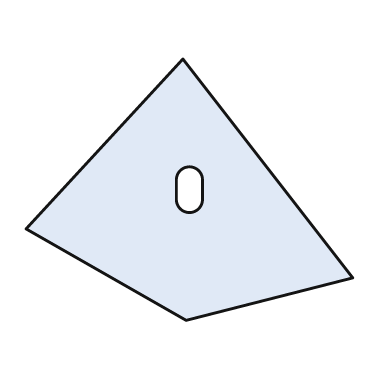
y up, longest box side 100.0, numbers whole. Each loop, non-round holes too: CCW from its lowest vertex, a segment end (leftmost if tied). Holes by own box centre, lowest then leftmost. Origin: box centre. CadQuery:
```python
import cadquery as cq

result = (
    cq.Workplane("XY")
    .moveTo(-1.0, -40.0)
    .lineTo(50.0, -27.0)
    .lineTo(-2.0, 40.0)
    .lineTo(-50.0, -12.0)
    .close()
    .moveTo(-4.0, -3.0)
    .threePointArc((0.0, -7.0), (4.0, -3.0))
    .lineTo(4.0, 3.0)
    .threePointArc((0.0, 7.0), (-4.0, 3.0))
    .close()
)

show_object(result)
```